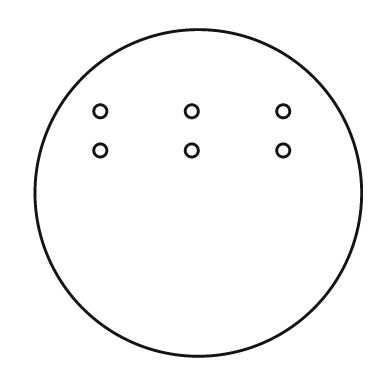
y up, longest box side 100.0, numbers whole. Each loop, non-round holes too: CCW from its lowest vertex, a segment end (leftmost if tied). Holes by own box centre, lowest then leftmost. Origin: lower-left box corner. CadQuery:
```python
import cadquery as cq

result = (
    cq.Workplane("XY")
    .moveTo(50.0, 50.0)
    .circle(50.0)
    .moveTo(20.0, 63.0)
    .circle(2.0)
    .moveTo(48.0, 63.0)
    .circle(2.0)
    .moveTo(76.0, 63.0)
    .circle(2.0)
    .moveTo(20.0, 75.0)
    .circle(2.0)
    .moveTo(48.0, 75.0)
    .circle(2.0)
    .moveTo(76.0, 75.0)
    .circle(2.0)
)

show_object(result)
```